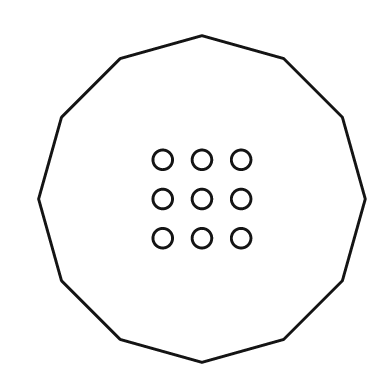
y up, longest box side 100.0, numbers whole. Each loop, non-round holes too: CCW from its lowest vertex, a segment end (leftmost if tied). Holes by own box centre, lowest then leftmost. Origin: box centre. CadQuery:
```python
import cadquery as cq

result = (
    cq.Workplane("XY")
    .moveTo(0.0, -50.0)
    .lineTo(25.0, -43.0)
    .lineTo(43.0, -25.0)
    .lineTo(50.0, 0.0)
    .lineTo(43.0, 25.0)
    .lineTo(25.0, 43.0)
    .lineTo(0.0, 50.0)
    .lineTo(-25.0, 43.0)
    .lineTo(-43.0, 25.0)
    .lineTo(-50.0, 0.0)
    .lineTo(-43.0, -25.0)
    .lineTo(-25.0, -43.0)
    .close()
    .moveTo(-12.0, -12.0)
    .circle(3.0)
    .moveTo(0.0, -12.0)
    .circle(3.0)
    .moveTo(12.0, -12.0)
    .circle(3.0)
    .moveTo(-12.0, 0.0)
    .circle(3.0)
    .moveTo(0.0, 0.0)
    .circle(3.0)
    .moveTo(12.0, 0.0)
    .circle(3.0)
    .moveTo(-12.0, 12.0)
    .circle(3.0)
    .moveTo(0.0, 12.0)
    .circle(3.0)
    .moveTo(12.0, 12.0)
    .circle(3.0)
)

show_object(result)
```